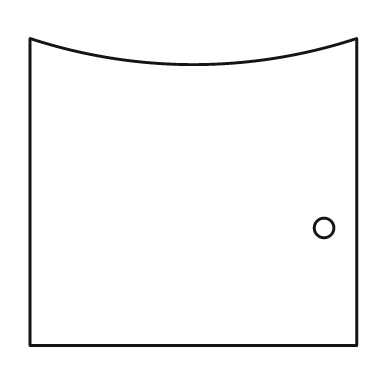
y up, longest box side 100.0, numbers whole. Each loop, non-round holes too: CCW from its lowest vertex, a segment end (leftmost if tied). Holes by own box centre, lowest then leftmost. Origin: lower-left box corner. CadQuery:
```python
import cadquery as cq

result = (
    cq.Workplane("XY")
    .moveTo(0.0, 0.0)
    .lineTo(100.0, 0.0)
    .lineTo(100.0, 94.0)
    .threePointArc((50.0, 86.0), (0.0, 94.0))
    .close()
    .moveTo(90.0, 36.0)
    .circle(3.0)
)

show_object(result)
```